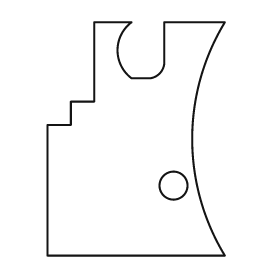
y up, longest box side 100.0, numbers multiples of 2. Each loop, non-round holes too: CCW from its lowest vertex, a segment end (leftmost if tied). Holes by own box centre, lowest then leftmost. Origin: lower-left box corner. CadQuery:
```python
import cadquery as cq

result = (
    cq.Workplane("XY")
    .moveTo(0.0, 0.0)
    .lineTo(76.0, 0.0)
    .threePointArc((62.0, 50.0), (76.0, 100.0))
    .lineTo(50.0, 100.0)
    .lineTo(50.0, 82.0)
    .threePointArc((48.0, 78.0), (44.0, 76.0))
    .lineTo(36.0, 76.0)
    .threePointArc((30.0, 88.0), (36.0, 100.0))
    .lineTo(20.0, 100.0)
    .lineTo(20.0, 66.0)
    .lineTo(10.0, 66.0)
    .lineTo(10.0, 56.0)
    .lineTo(0.0, 56.0)
    .close()
    .moveTo(54.0, 30.0)
    .circle(6.0)
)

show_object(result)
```